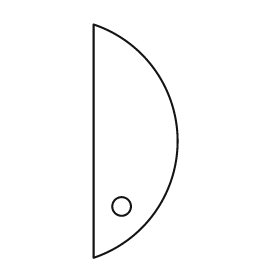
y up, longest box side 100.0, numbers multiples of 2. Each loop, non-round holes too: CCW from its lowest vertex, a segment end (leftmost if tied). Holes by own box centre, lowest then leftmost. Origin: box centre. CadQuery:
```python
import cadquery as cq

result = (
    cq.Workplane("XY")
    .moveTo(-18.0, -50.0)
    .threePointArc((18.0, 0.0), (-18.0, 50.0))
    .close()
    .moveTo(-6.0, -28.0)
    .circle(4.0)
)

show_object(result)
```